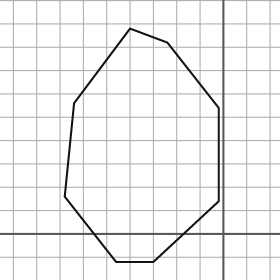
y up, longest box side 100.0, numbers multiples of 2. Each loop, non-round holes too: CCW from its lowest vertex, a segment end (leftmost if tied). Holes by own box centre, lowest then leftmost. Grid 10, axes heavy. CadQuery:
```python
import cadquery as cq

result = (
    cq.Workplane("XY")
    .moveTo(-46.0, -12.0)
    .lineTo(-30.0, -12.0)
    .lineTo(-2.0, 14.0)
    .lineTo(-2.0, 54.0)
    .lineTo(-24.0, 82.0)
    .lineTo(-40.0, 88.0)
    .lineTo(-64.0, 56.0)
    .lineTo(-68.0, 16.0)
    .close()
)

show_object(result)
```